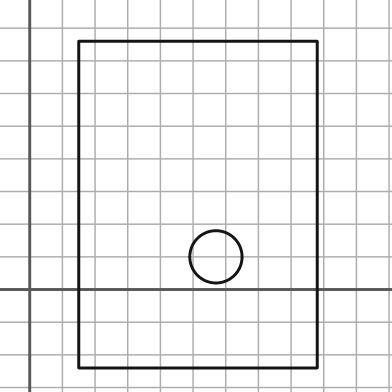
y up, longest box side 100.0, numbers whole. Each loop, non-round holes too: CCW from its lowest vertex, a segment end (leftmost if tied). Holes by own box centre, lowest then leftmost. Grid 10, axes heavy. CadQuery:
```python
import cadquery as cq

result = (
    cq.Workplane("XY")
    .moveTo(15.0, -24.0)
    .lineTo(88.0, -24.0)
    .lineTo(88.0, 76.0)
    .lineTo(15.0, 76.0)
    .close()
    .moveTo(57.0, 10.0)
    .circle(8.0)
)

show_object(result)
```